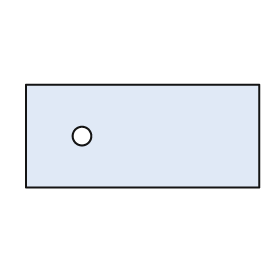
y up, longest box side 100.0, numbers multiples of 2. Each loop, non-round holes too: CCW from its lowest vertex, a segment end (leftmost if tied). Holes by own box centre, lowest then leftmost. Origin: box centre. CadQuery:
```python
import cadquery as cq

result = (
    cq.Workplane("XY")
    .moveTo(-50.0, -22.0)
    .lineTo(50.0, -22.0)
    .lineTo(50.0, 22.0)
    .lineTo(-50.0, 22.0)
    .close()
    .moveTo(-26.0, 0.0)
    .circle(4.0)
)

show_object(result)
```